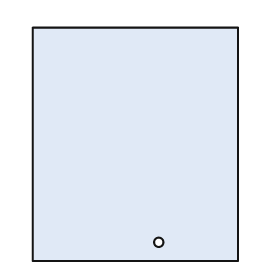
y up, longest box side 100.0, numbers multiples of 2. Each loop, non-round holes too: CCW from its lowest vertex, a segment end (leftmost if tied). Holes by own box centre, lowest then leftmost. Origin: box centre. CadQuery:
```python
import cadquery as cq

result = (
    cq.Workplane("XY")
    .moveTo(-44.0, -50.0)
    .lineTo(44.0, -50.0)
    .lineTo(44.0, 50.0)
    .lineTo(-44.0, 50.0)
    .close()
    .moveTo(10.0, -42.0)
    .circle(2.0)
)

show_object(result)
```